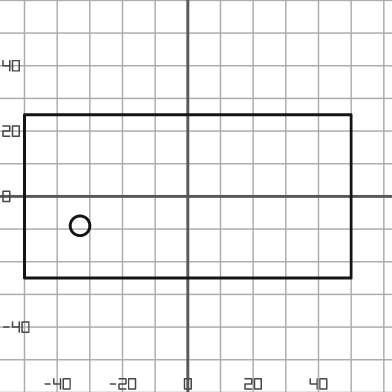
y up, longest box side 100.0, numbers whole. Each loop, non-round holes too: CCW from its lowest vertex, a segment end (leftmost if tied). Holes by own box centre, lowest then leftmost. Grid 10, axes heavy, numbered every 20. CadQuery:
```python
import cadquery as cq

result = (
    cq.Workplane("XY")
    .moveTo(-50.0, -25.0)
    .lineTo(50.0, -25.0)
    .lineTo(50.0, 25.0)
    .lineTo(-50.0, 25.0)
    .close()
    .moveTo(-33.0, -9.0)
    .circle(3.0)
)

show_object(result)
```